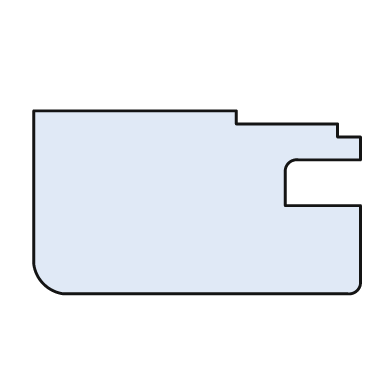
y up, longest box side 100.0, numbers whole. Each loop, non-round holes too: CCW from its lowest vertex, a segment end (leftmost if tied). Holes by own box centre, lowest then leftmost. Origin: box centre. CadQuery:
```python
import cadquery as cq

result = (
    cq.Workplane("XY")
    .moveTo(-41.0, -28.0)
    .lineTo(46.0, -28.0)
    .threePointArc((49.0, -27.0), (50.0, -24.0))
    .lineTo(50.0, -1.0)
    .lineTo(27.0, -1.0)
    .lineTo(27.0, 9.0)
    .threePointArc((28.0, 12.0), (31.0, 13.0))
    .lineTo(50.0, 13.0)
    .lineTo(50.0, 20.0)
    .lineTo(43.0, 20.0)
    .lineTo(43.0, 24.0)
    .lineTo(12.0, 24.0)
    .lineTo(12.0, 28.0)
    .lineTo(-50.0, 28.0)
    .lineTo(-50.0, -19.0)
    .threePointArc((-47.0, -25.0), (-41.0, -28.0))
    .close()
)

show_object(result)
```